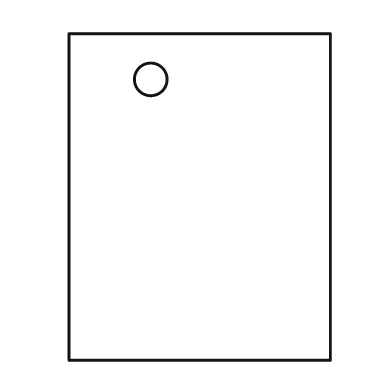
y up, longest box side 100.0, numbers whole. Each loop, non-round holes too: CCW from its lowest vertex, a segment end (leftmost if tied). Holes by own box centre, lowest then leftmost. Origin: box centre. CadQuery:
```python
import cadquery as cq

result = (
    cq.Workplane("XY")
    .moveTo(-40.0, -50.0)
    .lineTo(40.0, -50.0)
    .lineTo(40.0, 50.0)
    .lineTo(-40.0, 50.0)
    .close()
    .moveTo(-15.0, 36.0)
    .circle(5.0)
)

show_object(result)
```